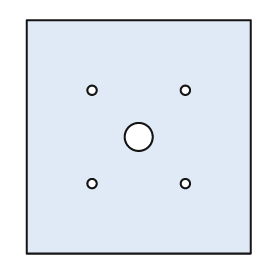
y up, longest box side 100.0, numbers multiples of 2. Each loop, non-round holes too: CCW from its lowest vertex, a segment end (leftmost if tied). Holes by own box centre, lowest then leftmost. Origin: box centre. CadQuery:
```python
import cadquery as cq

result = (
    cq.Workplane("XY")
    .moveTo(-48.0, -50.0)
    .lineTo(48.0, -50.0)
    .lineTo(48.0, 50.0)
    .lineTo(-48.0, 50.0)
    .close()
    .moveTo(-20.0, -20.0)
    .circle(2.0)
    .moveTo(20.0, -20.0)
    .circle(2.0)
    .moveTo(0.0, 0.0)
    .circle(6.0)
    .moveTo(-20.0, 20.0)
    .circle(2.0)
    .moveTo(20.0, 20.0)
    .circle(2.0)
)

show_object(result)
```